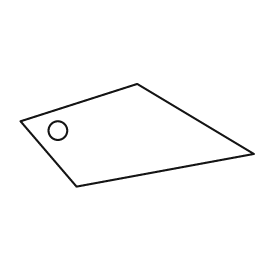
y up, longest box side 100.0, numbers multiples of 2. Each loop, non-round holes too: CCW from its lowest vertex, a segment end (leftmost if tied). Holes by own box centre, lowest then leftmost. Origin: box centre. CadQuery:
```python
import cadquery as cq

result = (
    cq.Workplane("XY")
    .moveTo(-26.0, -22.0)
    .lineTo(50.0, -8.0)
    .lineTo(0.0, 22.0)
    .lineTo(-50.0, 6.0)
    .close()
    .moveTo(-34.0, 2.0)
    .circle(4.0)
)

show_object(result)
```